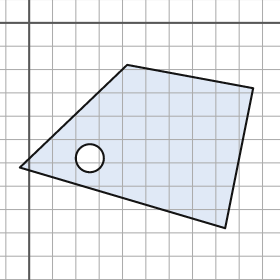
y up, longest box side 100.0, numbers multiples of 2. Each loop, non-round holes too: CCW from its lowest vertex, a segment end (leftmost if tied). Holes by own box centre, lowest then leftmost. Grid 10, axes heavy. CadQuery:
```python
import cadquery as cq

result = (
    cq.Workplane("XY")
    .moveTo(84.0, -88.0)
    .lineTo(96.0, -28.0)
    .lineTo(42.0, -18.0)
    .lineTo(-4.0, -62.0)
    .close()
    .moveTo(26.0, -58.0)
    .circle(6.0)
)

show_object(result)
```